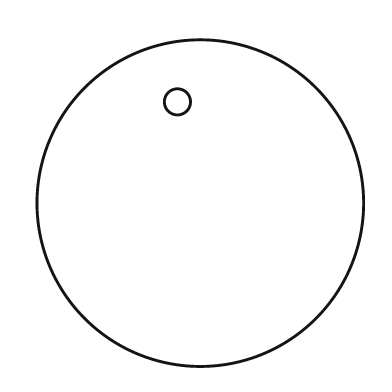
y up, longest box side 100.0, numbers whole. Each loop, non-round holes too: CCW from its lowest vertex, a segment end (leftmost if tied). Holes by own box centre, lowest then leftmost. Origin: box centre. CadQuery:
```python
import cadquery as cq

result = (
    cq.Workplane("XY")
    .moveTo(0.0, 0.0)
    .circle(50.0)
    .moveTo(-7.0, 31.0)
    .circle(4.0)
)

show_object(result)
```